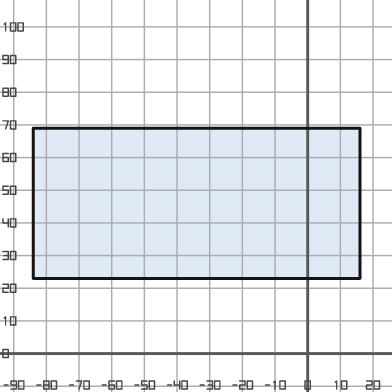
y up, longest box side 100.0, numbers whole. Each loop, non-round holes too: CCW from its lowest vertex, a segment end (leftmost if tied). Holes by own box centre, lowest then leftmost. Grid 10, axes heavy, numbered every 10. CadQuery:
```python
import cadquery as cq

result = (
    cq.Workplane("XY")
    .moveTo(-84.0, 23.0)
    .lineTo(16.0, 23.0)
    .lineTo(16.0, 69.0)
    .lineTo(-84.0, 69.0)
    .close()
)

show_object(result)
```